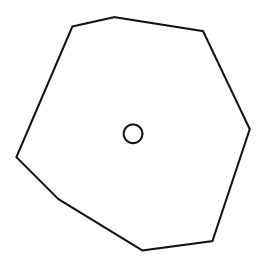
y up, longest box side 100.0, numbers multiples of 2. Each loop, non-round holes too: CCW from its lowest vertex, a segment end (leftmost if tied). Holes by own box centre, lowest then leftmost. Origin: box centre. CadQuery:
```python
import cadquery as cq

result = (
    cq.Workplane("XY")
    .moveTo(4.0, -50.0)
    .lineTo(34.0, -46.0)
    .lineTo(50.0, 2.0)
    .lineTo(30.0, 44.0)
    .lineTo(-8.0, 50.0)
    .lineTo(-26.0, 46.0)
    .lineTo(-50.0, -10.0)
    .lineTo(-32.0, -28.0)
    .close()
    .moveTo(0.0, 0.0)
    .circle(4.0)
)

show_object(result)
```